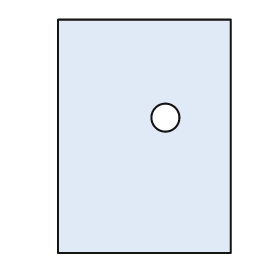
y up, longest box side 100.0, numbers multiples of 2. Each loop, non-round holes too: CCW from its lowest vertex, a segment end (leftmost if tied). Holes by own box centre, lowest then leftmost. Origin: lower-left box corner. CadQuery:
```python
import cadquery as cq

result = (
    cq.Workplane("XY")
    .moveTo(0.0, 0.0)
    .lineTo(74.0, 0.0)
    .lineTo(74.0, 100.0)
    .lineTo(0.0, 100.0)
    .close()
    .moveTo(46.0, 58.0)
    .circle(6.0)
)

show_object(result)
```